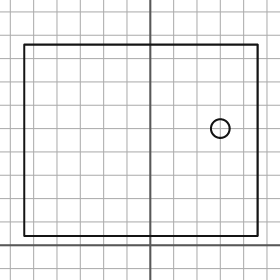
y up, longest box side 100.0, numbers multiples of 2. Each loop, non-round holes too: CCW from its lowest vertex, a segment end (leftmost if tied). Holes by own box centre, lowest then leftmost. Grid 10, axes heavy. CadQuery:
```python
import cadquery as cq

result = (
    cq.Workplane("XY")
    .moveTo(-54.0, 4.0)
    .lineTo(46.0, 4.0)
    .lineTo(46.0, 86.0)
    .lineTo(-54.0, 86.0)
    .close()
    .moveTo(30.0, 50.0)
    .circle(4.0)
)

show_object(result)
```